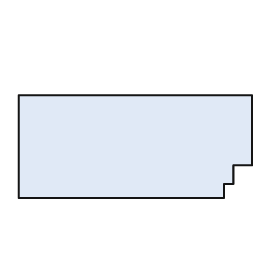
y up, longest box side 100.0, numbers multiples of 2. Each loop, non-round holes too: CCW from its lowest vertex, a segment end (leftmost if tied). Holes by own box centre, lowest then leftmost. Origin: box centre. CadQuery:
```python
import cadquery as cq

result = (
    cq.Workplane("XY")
    .moveTo(-50.0, -22.0)
    .lineTo(38.0, -22.0)
    .lineTo(38.0, -16.0)
    .lineTo(42.0, -16.0)
    .lineTo(42.0, -8.0)
    .lineTo(50.0, -8.0)
    .lineTo(50.0, 22.0)
    .lineTo(-50.0, 22.0)
    .close()
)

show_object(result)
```